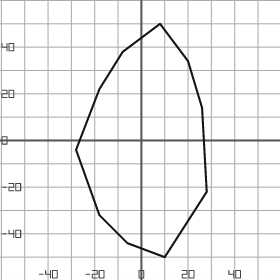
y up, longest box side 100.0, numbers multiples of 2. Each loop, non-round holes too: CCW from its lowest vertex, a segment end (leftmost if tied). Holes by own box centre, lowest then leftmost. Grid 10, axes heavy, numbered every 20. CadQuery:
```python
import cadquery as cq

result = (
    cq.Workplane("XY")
    .moveTo(10.0, -50.0)
    .lineTo(28.0, -22.0)
    .lineTo(26.0, 14.0)
    .lineTo(20.0, 34.0)
    .lineTo(8.0, 50.0)
    .lineTo(-8.0, 38.0)
    .lineTo(-18.0, 22.0)
    .lineTo(-28.0, -4.0)
    .lineTo(-18.0, -32.0)
    .lineTo(-6.0, -44.0)
    .close()
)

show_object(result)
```